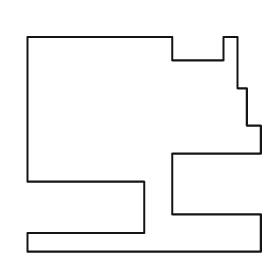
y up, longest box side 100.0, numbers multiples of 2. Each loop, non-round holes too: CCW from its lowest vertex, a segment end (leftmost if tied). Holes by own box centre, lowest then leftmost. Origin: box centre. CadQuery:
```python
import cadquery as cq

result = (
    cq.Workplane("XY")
    .moveTo(-50.0, -46.0)
    .lineTo(50.0, -46.0)
    .lineTo(50.0, -30.0)
    .lineTo(12.0, -30.0)
    .lineTo(12.0, -4.0)
    .lineTo(50.0, -4.0)
    .lineTo(50.0, 8.0)
    .lineTo(44.0, 8.0)
    .lineTo(44.0, 24.0)
    .lineTo(40.0, 24.0)
    .lineTo(40.0, 46.0)
    .lineTo(34.0, 46.0)
    .lineTo(34.0, 36.0)
    .lineTo(12.0, 36.0)
    .lineTo(12.0, 46.0)
    .lineTo(-50.0, 46.0)
    .lineTo(-50.0, -16.0)
    .lineTo(0.0, -16.0)
    .lineTo(0.0, -38.0)
    .lineTo(-50.0, -38.0)
    .close()
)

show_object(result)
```